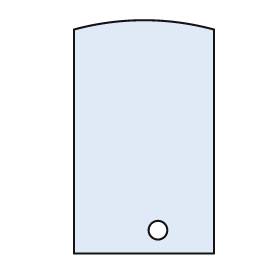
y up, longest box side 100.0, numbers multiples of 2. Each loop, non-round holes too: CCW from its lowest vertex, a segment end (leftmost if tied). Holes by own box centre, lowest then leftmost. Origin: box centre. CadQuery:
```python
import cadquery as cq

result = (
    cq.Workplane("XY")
    .moveTo(-30.0, -50.0)
    .lineTo(30.0, -50.0)
    .lineTo(30.0, 46.0)
    .threePointArc((0.0, 50.0), (-30.0, 46.0))
    .close()
    .moveTo(6.0, -40.0)
    .circle(4.0)
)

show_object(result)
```